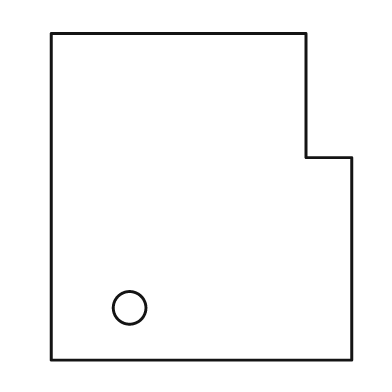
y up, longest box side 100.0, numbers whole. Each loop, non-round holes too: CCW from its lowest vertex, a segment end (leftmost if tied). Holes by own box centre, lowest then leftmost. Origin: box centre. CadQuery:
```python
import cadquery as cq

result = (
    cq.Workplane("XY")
    .moveTo(-46.0, -50.0)
    .lineTo(46.0, -50.0)
    .lineTo(46.0, 12.0)
    .lineTo(32.0, 12.0)
    .lineTo(32.0, 50.0)
    .lineTo(-46.0, 50.0)
    .close()
    .moveTo(-22.0, -34.0)
    .circle(5.0)
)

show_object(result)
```